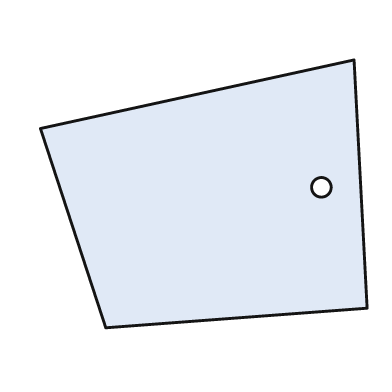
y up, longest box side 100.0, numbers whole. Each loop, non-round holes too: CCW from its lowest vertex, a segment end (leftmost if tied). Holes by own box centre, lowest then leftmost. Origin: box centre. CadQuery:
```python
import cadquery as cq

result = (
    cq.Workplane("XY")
    .moveTo(-30.0, -41.0)
    .lineTo(50.0, -35.0)
    .lineTo(46.0, 41.0)
    .lineTo(-50.0, 20.0)
    .close()
    .moveTo(36.0, 2.0)
    .circle(3.0)
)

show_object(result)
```